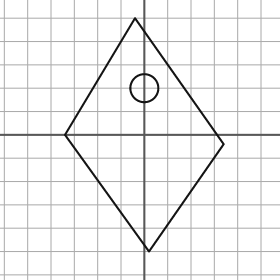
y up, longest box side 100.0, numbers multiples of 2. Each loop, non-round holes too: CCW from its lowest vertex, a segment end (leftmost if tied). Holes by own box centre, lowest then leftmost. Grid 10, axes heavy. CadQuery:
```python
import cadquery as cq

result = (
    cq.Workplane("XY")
    .moveTo(2.0, -50.0)
    .lineTo(34.0, -4.0)
    .lineTo(-4.0, 50.0)
    .lineTo(-34.0, 0.0)
    .close()
    .moveTo(0.0, 20.0)
    .circle(6.0)
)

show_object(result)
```